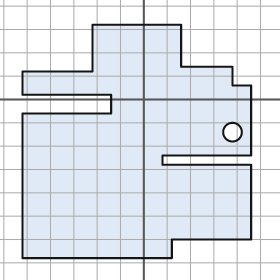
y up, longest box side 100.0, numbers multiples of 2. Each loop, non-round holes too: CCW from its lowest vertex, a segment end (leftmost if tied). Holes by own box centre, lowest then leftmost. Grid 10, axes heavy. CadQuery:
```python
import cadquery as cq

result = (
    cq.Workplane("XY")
    .moveTo(-52.0, -68.0)
    .lineTo(12.0, -68.0)
    .lineTo(12.0, -60.0)
    .lineTo(46.0, -60.0)
    .lineTo(46.0, -28.0)
    .lineTo(8.0, -28.0)
    .lineTo(8.0, -24.0)
    .lineTo(46.0, -24.0)
    .lineTo(46.0, 6.0)
    .lineTo(38.0, 6.0)
    .lineTo(38.0, 14.0)
    .lineTo(16.0, 14.0)
    .lineTo(16.0, 32.0)
    .lineTo(-22.0, 32.0)
    .lineTo(-22.0, 12.0)
    .lineTo(-52.0, 12.0)
    .lineTo(-52.0, 2.0)
    .lineTo(-14.0, 2.0)
    .lineTo(-14.0, -6.0)
    .lineTo(-52.0, -6.0)
    .close()
    .moveTo(38.0, -14.0)
    .circle(4.0)
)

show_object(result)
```